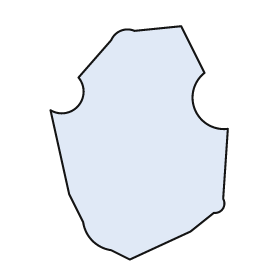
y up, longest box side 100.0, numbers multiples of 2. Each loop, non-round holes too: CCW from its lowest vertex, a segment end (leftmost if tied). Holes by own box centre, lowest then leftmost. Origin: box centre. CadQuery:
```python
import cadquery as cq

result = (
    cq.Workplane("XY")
    .moveTo(-4.0, -50.0)
    .lineTo(22.0, -38.0)
    .lineTo(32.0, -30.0)
    .threePointArc((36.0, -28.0), (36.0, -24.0))
    .lineTo(38.0, 6.0)
    .threePointArc((24.0, 14.0), (28.0, 30.0))
    .lineTo(18.0, 50.0)
    .lineTo(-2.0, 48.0)
    .threePointArc((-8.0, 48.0), (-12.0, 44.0))
    .lineTo(-26.0, 28.0)
    .threePointArc((-26.0, 16.0), (-38.0, 14.0))
    .lineTo(-30.0, -22.0)
    .lineTo(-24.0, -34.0)
    .threePointArc((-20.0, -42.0), (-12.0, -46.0))
    .close()
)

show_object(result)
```